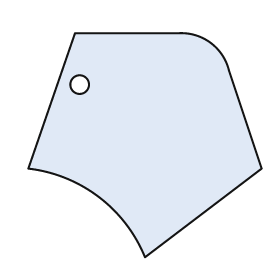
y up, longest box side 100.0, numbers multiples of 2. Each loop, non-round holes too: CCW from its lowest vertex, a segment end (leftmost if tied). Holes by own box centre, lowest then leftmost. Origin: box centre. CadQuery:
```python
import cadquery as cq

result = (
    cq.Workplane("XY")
    .moveTo(0.0, -48.0)
    .lineTo(50.0, -10.0)
    .lineTo(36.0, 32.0)
    .threePointArc((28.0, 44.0), (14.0, 48.0))
    .lineTo(-30.0, 48.0)
    .lineTo(-50.0, -10.0)
    .threePointArc((-20.0, -22.0), (0.0, -48.0))
    .close()
    .moveTo(-28.0, 26.0)
    .circle(4.0)
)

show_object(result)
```